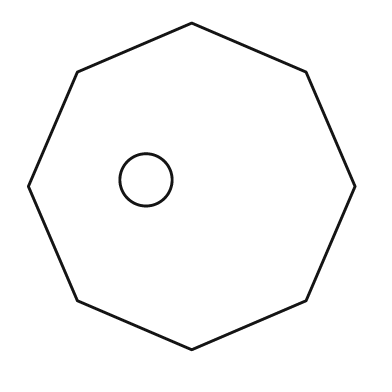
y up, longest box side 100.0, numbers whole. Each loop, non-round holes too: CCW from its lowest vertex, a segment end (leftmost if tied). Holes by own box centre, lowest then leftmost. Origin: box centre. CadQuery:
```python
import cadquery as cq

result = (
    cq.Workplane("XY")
    .moveTo(0.0, -50.0)
    .lineTo(35.0, -35.0)
    .lineTo(50.0, 0.0)
    .lineTo(35.0, 35.0)
    .lineTo(0.0, 50.0)
    .lineTo(-35.0, 35.0)
    .lineTo(-50.0, 0.0)
    .lineTo(-35.0, -35.0)
    .close()
    .moveTo(-14.0, 2.0)
    .circle(8.0)
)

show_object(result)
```